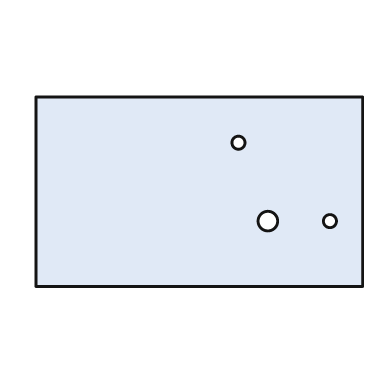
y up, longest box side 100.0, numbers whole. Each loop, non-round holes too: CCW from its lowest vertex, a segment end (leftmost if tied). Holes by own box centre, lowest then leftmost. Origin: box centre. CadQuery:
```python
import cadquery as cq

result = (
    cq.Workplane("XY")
    .moveTo(-50.0, -29.0)
    .lineTo(50.0, -29.0)
    .lineTo(50.0, 29.0)
    .lineTo(-50.0, 29.0)
    .close()
    .moveTo(21.0, -9.0)
    .circle(3.0)
    .moveTo(40.0, -9.0)
    .circle(2.0)
    .moveTo(12.0, 15.0)
    .circle(2.0)
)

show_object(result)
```